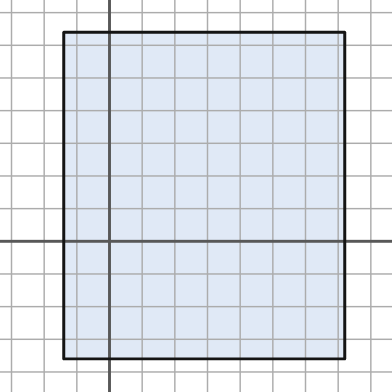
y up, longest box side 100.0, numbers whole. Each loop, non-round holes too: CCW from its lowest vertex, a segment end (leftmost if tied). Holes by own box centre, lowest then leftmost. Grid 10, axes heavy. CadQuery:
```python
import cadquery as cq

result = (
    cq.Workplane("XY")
    .moveTo(-14.0, -36.0)
    .lineTo(72.0, -36.0)
    .lineTo(72.0, 64.0)
    .lineTo(-14.0, 64.0)
    .close()
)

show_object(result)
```